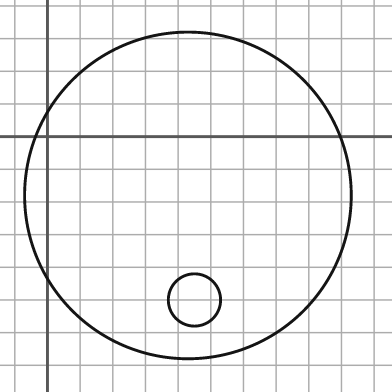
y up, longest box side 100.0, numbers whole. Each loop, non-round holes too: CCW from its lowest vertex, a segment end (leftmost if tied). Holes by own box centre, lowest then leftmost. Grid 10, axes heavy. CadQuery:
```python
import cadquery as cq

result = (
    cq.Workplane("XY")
    .moveTo(43.0, -18.0)
    .circle(50.0)
    .moveTo(45.0, -50.0)
    .circle(8.0)
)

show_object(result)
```